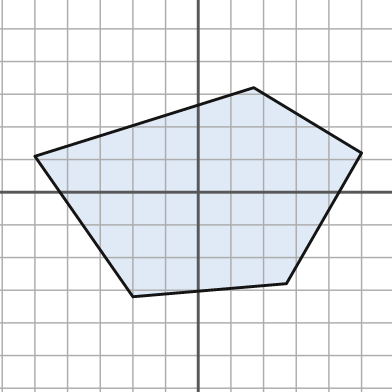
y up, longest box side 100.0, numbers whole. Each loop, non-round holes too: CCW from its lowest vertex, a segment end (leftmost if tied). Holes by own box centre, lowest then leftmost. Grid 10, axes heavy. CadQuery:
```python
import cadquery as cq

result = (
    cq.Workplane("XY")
    .moveTo(-20.0, -32.0)
    .lineTo(27.0, -28.0)
    .lineTo(50.0, 12.0)
    .lineTo(17.0, 32.0)
    .lineTo(-50.0, 11.0)
    .close()
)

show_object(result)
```